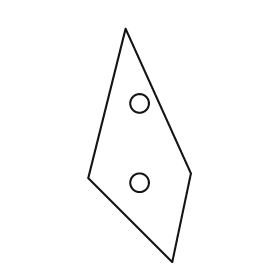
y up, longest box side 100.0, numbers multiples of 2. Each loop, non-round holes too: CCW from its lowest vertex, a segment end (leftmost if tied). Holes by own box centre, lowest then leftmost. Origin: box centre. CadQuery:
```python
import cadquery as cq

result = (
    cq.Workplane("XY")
    .moveTo(14.0, -50.0)
    .lineTo(22.0, -12.0)
    .lineTo(-6.0, 50.0)
    .lineTo(-22.0, -14.0)
    .close()
    .moveTo(0.0, -16.0)
    .circle(4.0)
    .moveTo(0.0, 18.0)
    .circle(4.0)
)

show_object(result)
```